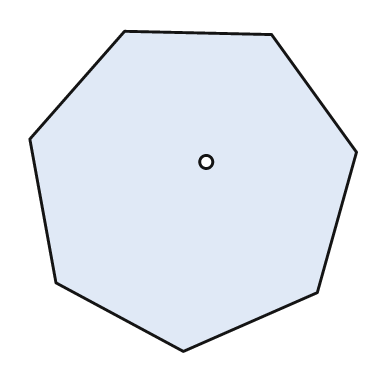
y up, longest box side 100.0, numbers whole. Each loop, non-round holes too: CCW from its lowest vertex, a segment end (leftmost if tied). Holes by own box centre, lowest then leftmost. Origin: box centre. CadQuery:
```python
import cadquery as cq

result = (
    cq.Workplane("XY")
    .moveTo(-3.0, -49.0)
    .lineTo(38.0, -31.0)
    .lineTo(50.0, 12.0)
    .lineTo(24.0, 48.0)
    .lineTo(-21.0, 49.0)
    .lineTo(-50.0, 16.0)
    .lineTo(-42.0, -28.0)
    .close()
    .moveTo(4.0, 9.0)
    .circle(2.0)
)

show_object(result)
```